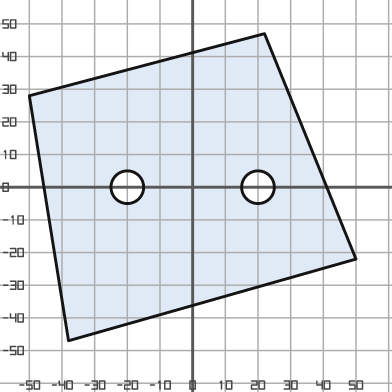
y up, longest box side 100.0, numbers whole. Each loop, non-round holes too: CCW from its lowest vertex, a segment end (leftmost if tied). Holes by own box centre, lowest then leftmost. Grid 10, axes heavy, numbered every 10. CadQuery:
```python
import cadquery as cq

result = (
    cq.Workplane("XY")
    .moveTo(-38.0, -47.0)
    .lineTo(50.0, -22.0)
    .lineTo(22.0, 47.0)
    .lineTo(-50.0, 28.0)
    .close()
    .moveTo(-20.0, 0.0)
    .circle(5.0)
    .moveTo(20.0, 0.0)
    .circle(5.0)
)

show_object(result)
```